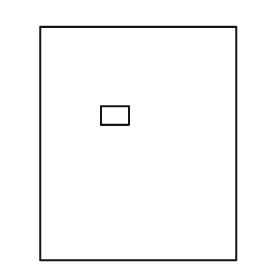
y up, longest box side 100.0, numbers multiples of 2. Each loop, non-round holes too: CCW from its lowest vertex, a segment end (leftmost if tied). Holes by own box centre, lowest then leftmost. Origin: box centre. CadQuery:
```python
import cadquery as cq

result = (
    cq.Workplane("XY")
    .moveTo(-42.0, -50.0)
    .lineTo(42.0, -50.0)
    .lineTo(42.0, 50.0)
    .lineTo(-42.0, 50.0)
    .close()
    .moveTo(-16.0, 8.0)
    .lineTo(-4.0, 8.0)
    .lineTo(-4.0, 16.0)
    .lineTo(-16.0, 16.0)
    .close()
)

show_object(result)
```